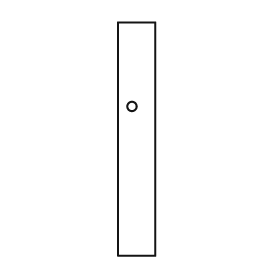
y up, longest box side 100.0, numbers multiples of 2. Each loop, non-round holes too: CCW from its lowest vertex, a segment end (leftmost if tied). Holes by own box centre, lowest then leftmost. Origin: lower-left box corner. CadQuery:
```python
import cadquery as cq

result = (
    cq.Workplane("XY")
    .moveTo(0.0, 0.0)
    .lineTo(16.0, 0.0)
    .lineTo(16.0, 100.0)
    .lineTo(0.0, 100.0)
    .close()
    .moveTo(6.0, 64.0)
    .circle(2.0)
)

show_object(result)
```